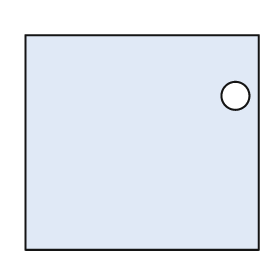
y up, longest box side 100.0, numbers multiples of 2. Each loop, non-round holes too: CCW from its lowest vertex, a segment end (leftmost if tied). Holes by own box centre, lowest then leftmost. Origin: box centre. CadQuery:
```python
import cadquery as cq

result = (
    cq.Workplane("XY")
    .moveTo(-50.0, -46.0)
    .lineTo(50.0, -46.0)
    .lineTo(50.0, 46.0)
    .lineTo(-50.0, 46.0)
    .close()
    .moveTo(40.0, 20.0)
    .circle(6.0)
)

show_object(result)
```